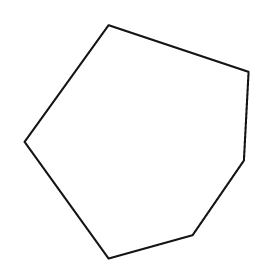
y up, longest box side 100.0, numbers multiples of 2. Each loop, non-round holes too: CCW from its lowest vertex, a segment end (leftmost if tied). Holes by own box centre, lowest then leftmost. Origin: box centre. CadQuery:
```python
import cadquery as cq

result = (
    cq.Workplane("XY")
    .moveTo(-12.0, -50.0)
    .lineTo(24.0, -40.0)
    .lineTo(46.0, -8.0)
    .lineTo(48.0, 30.0)
    .lineTo(-12.0, 50.0)
    .lineTo(-48.0, 0.0)
    .close()
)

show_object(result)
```